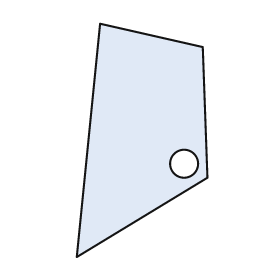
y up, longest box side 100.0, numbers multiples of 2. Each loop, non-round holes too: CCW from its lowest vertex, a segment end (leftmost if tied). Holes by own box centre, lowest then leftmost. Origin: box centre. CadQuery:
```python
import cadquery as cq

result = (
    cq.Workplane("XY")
    .moveTo(-28.0, -50.0)
    .lineTo(28.0, -16.0)
    .lineTo(26.0, 40.0)
    .lineTo(-18.0, 50.0)
    .close()
    .moveTo(18.0, -10.0)
    .circle(6.0)
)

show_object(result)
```